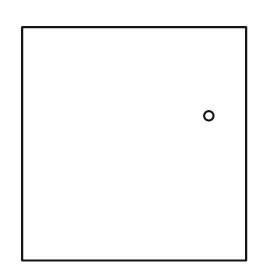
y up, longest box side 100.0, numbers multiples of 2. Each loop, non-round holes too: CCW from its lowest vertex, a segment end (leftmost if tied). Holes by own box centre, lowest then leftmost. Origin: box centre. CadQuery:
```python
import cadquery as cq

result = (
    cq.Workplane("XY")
    .moveTo(-48.0, -50.0)
    .lineTo(48.0, -50.0)
    .lineTo(48.0, 50.0)
    .lineTo(-48.0, 50.0)
    .close()
    .moveTo(32.0, 12.0)
    .circle(2.0)
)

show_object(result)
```